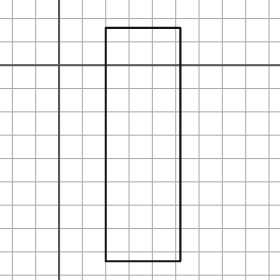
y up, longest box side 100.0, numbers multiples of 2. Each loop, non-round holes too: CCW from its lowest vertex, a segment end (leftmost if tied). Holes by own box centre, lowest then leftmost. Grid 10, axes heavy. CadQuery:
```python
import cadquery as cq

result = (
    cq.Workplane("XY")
    .moveTo(20.0, -84.0)
    .lineTo(52.0, -84.0)
    .lineTo(52.0, 16.0)
    .lineTo(20.0, 16.0)
    .close()
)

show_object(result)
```